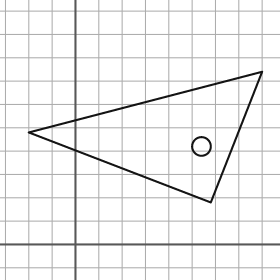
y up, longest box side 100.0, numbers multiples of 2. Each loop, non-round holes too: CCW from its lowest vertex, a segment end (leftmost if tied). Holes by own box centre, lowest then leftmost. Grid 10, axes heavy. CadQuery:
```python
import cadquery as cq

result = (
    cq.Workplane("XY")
    .moveTo(58.0, 18.0)
    .lineTo(80.0, 74.0)
    .lineTo(-20.0, 48.0)
    .close()
    .moveTo(54.0, 42.0)
    .circle(4.0)
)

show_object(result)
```